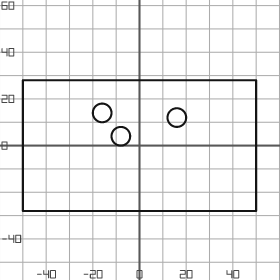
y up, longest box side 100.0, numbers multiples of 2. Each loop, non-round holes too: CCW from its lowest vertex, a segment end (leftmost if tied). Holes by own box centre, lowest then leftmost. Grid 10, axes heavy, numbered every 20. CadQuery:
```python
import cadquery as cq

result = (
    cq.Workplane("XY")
    .moveTo(-50.0, -28.0)
    .lineTo(50.0, -28.0)
    .lineTo(50.0, 28.0)
    .lineTo(-50.0, 28.0)
    .close()
    .moveTo(-8.0, 4.0)
    .circle(4.0)
    .moveTo(16.0, 12.0)
    .circle(4.0)
    .moveTo(-16.0, 14.0)
    .circle(4.0)
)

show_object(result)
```